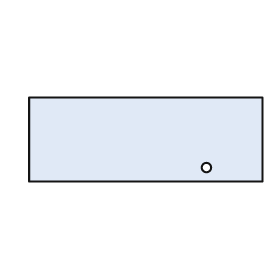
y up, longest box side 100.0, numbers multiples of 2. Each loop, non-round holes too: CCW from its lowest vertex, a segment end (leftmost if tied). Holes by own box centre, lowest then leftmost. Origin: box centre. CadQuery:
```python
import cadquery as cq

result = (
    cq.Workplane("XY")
    .moveTo(-50.0, -18.0)
    .lineTo(50.0, -18.0)
    .lineTo(50.0, 18.0)
    .lineTo(-50.0, 18.0)
    .close()
    .moveTo(26.0, -12.0)
    .circle(2.0)
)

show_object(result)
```